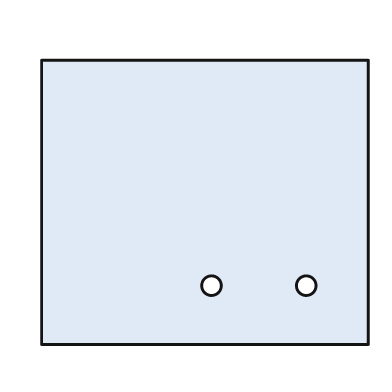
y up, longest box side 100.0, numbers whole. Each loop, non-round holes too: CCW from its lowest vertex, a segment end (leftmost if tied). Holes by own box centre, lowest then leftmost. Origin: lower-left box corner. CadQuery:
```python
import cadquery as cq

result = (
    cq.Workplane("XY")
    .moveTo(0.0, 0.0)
    .lineTo(100.0, 0.0)
    .lineTo(100.0, 87.0)
    .lineTo(0.0, 87.0)
    .close()
    .moveTo(52.0, 18.0)
    .circle(3.0)
    .moveTo(81.0, 18.0)
    .circle(3.0)
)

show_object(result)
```